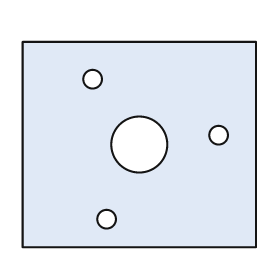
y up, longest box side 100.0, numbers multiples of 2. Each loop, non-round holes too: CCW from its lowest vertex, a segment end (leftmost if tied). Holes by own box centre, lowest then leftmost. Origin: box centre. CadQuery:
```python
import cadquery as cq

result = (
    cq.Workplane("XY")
    .moveTo(-50.0, -44.0)
    .lineTo(50.0, -44.0)
    .lineTo(50.0, 44.0)
    .lineTo(-50.0, 44.0)
    .close()
    .moveTo(-14.0, -32.0)
    .circle(4.0)
    .moveTo(0.0, 0.0)
    .circle(12.0)
    .moveTo(34.0, 4.0)
    .circle(4.0)
    .moveTo(-20.0, 28.0)
    .circle(4.0)
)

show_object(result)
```